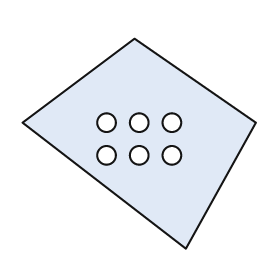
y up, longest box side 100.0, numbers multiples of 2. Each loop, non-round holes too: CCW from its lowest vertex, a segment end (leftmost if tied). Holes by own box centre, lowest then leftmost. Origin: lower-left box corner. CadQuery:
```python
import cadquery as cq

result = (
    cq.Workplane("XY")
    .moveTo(70.0, 0.0)
    .lineTo(100.0, 54.0)
    .lineTo(48.0, 90.0)
    .lineTo(0.0, 54.0)
    .close()
    .moveTo(36.0, 40.0)
    .circle(4.0)
    .moveTo(50.0, 40.0)
    .circle(4.0)
    .moveTo(64.0, 40.0)
    .circle(4.0)
    .moveTo(36.0, 54.0)
    .circle(4.0)
    .moveTo(50.0, 54.0)
    .circle(4.0)
    .moveTo(64.0, 54.0)
    .circle(4.0)
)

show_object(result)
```